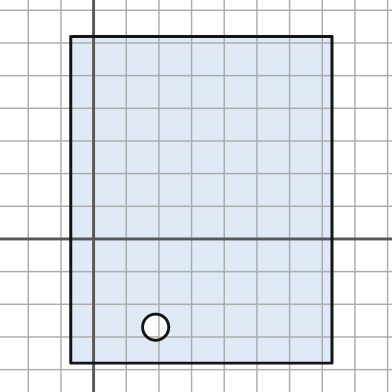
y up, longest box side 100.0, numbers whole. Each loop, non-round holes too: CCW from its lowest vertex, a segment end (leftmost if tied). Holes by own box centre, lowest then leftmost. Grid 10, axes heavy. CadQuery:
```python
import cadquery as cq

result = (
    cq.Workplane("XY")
    .moveTo(-7.0, -38.0)
    .lineTo(73.0, -38.0)
    .lineTo(73.0, 62.0)
    .lineTo(-7.0, 62.0)
    .close()
    .moveTo(19.0, -27.0)
    .circle(4.0)
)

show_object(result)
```